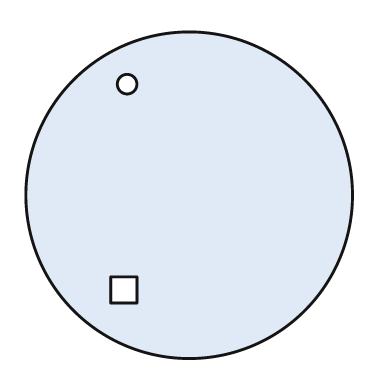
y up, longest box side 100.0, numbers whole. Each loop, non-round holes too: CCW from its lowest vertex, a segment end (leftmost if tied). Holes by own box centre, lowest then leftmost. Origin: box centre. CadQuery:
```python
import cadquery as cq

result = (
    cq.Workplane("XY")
    .moveTo(0.0, 0.0)
    .circle(50.0)
    .moveTo(-24.0, -33.0)
    .lineTo(-16.0, -33.0)
    .lineTo(-16.0, -25.0)
    .lineTo(-24.0, -25.0)
    .close()
    .moveTo(-19.0, 34.0)
    .circle(3.0)
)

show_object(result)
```